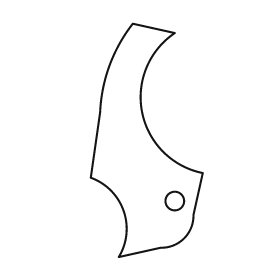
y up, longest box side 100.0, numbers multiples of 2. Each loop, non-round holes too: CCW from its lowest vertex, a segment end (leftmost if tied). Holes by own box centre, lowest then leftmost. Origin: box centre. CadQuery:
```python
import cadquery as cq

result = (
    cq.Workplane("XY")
    .moveTo(-12.0, -50.0)
    .lineTo(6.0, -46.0)
    .threePointArc((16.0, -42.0), (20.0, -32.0))
    .lineTo(24.0, -14.0)
    .threePointArc((-2.0, 12.0), (12.0, 46.0))
    .lineTo(-6.0, 50.0)
    .threePointArc((-16.0, 32.0), (-20.0, 12.0))
    .lineTo(-24.0, -16.0)
    .threePointArc((-10.0, -30.0), (-12.0, -50.0))
    .close()
    .moveTo(12.0, -26.0)
    .circle(4.0)
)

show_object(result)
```